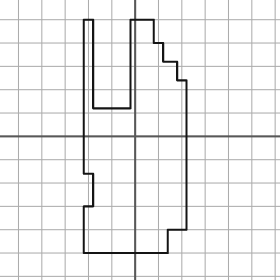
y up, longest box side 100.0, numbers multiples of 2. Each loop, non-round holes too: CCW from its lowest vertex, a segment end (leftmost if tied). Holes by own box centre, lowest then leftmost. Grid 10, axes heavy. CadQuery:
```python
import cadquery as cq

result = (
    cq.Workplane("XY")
    .moveTo(-22.0, -50.0)
    .lineTo(14.0, -50.0)
    .lineTo(14.0, -40.0)
    .lineTo(22.0, -40.0)
    .lineTo(22.0, 24.0)
    .lineTo(18.0, 24.0)
    .lineTo(18.0, 32.0)
    .lineTo(12.0, 32.0)
    .lineTo(12.0, 40.0)
    .lineTo(8.0, 40.0)
    .lineTo(8.0, 50.0)
    .lineTo(-2.0, 50.0)
    .lineTo(-2.0, 12.0)
    .lineTo(-18.0, 12.0)
    .lineTo(-18.0, 50.0)
    .lineTo(-22.0, 50.0)
    .lineTo(-22.0, -16.0)
    .lineTo(-18.0, -16.0)
    .lineTo(-18.0, -30.0)
    .lineTo(-22.0, -30.0)
    .close()
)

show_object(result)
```